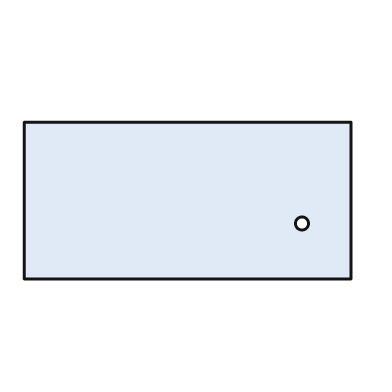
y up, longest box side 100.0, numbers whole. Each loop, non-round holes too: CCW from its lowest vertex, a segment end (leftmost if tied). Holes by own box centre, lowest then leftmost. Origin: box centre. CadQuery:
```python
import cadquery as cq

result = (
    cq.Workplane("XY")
    .moveTo(-50.0, -24.0)
    .lineTo(50.0, -24.0)
    .lineTo(50.0, 24.0)
    .lineTo(-50.0, 24.0)
    .close()
    .moveTo(35.0, -7.0)
    .circle(2.0)
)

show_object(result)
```